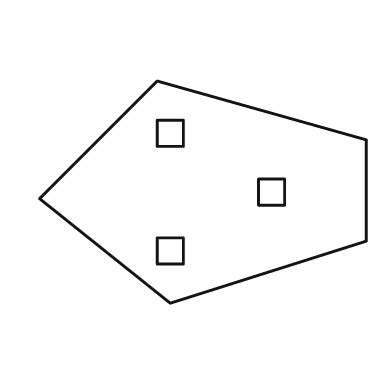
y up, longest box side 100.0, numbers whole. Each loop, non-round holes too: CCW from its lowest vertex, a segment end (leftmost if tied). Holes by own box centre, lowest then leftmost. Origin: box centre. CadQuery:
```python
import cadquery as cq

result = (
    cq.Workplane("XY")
    .moveTo(-10.0, -34.0)
    .lineTo(50.0, -15.0)
    .lineTo(50.0, 16.0)
    .lineTo(-14.0, 34.0)
    .lineTo(-50.0, -2.0)
    .close()
    .moveTo(-14.0, -22.0)
    .lineTo(-6.0, -22.0)
    .lineTo(-6.0, -14.0)
    .lineTo(-14.0, -14.0)
    .close()
    .moveTo(17.0, -4.0)
    .lineTo(25.0, -4.0)
    .lineTo(25.0, 4.0)
    .lineTo(17.0, 4.0)
    .close()
    .moveTo(-14.0, 14.0)
    .lineTo(-6.0, 14.0)
    .lineTo(-6.0, 22.0)
    .lineTo(-14.0, 22.0)
    .close()
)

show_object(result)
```